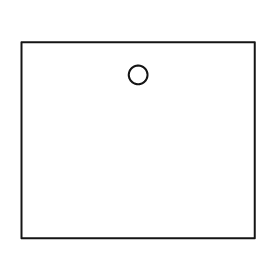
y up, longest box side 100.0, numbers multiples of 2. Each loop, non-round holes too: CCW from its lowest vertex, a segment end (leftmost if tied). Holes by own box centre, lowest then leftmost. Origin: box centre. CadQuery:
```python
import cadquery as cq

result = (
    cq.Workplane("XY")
    .moveTo(-50.0, -42.0)
    .lineTo(50.0, -42.0)
    .lineTo(50.0, 42.0)
    .lineTo(-50.0, 42.0)
    .close()
    .moveTo(0.0, 28.0)
    .circle(4.0)
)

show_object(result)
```